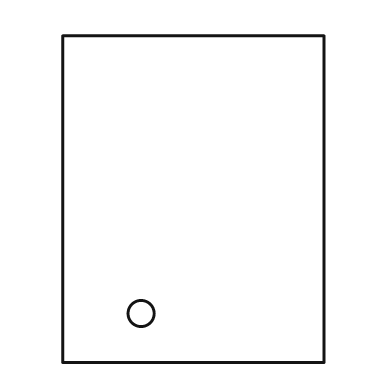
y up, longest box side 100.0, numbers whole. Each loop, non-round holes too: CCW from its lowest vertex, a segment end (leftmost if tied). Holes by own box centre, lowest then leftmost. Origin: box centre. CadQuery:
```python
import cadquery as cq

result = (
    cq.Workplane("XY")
    .moveTo(-40.0, -50.0)
    .lineTo(40.0, -50.0)
    .lineTo(40.0, 50.0)
    .lineTo(-40.0, 50.0)
    .close()
    .moveTo(-16.0, -35.0)
    .circle(4.0)
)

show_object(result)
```